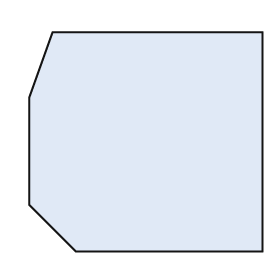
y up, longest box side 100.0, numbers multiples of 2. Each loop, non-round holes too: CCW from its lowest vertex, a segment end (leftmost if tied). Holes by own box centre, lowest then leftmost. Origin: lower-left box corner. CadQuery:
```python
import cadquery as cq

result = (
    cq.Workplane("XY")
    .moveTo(20.0, 0.0)
    .lineTo(100.0, 0.0)
    .lineTo(100.0, 94.0)
    .lineTo(10.0, 94.0)
    .lineTo(0.0, 66.0)
    .lineTo(0.0, 20.0)
    .close()
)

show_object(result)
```